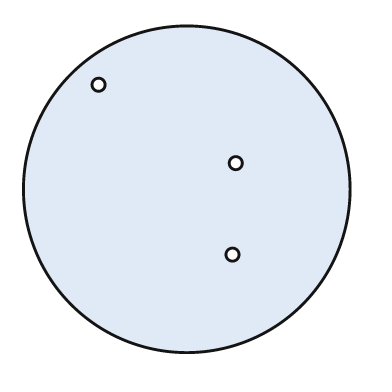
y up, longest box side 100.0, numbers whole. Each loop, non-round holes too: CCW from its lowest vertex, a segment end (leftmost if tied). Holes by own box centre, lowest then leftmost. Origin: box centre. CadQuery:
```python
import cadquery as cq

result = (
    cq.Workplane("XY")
    .moveTo(0.0, 0.0)
    .circle(50.0)
    .moveTo(14.0, -20.0)
    .circle(2.0)
    .moveTo(15.0, 8.0)
    .circle(2.0)
    .moveTo(-27.0, 32.0)
    .circle(2.0)
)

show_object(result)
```